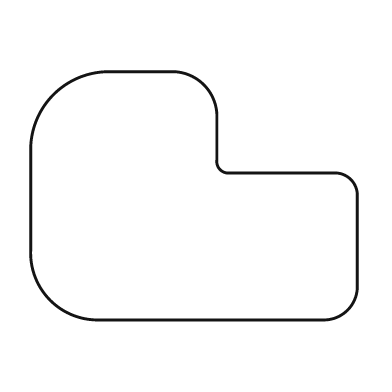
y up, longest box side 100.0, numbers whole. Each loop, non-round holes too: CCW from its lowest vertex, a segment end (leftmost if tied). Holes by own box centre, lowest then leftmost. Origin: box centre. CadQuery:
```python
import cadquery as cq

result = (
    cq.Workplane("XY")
    .moveTo(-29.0, -38.0)
    .lineTo(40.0, -38.0)
    .threePointArc((47.0, -35.0), (50.0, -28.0))
    .lineTo(50.0, 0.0)
    .threePointArc((48.0, 5.0), (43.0, 7.0))
    .lineTo(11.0, 7.0)
    .threePointArc((8.0, 8.0), (7.0, 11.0))
    .lineTo(7.0, 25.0)
    .threePointArc((3.0, 34.0), (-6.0, 38.0))
    .lineTo(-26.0, 38.0)
    .threePointArc((-43.0, 31.0), (-50.0, 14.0))
    .lineTo(-50.0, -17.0)
    .threePointArc((-44.0, -32.0), (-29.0, -38.0))
    .close()
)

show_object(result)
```